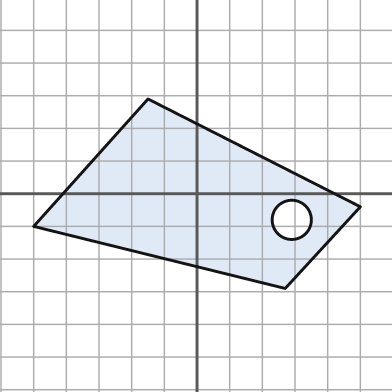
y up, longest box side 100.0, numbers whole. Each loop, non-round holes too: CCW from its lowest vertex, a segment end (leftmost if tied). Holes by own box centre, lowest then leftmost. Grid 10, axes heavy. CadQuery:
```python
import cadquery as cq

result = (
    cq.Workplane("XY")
    .moveTo(27.0, -29.0)
    .lineTo(50.0, -4.0)
    .lineTo(-15.0, 29.0)
    .lineTo(-50.0, -10.0)
    .close()
    .moveTo(29.0, -8.0)
    .circle(6.0)
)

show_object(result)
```